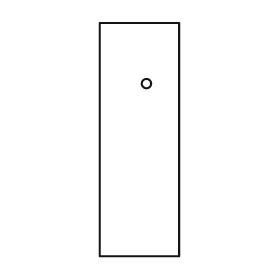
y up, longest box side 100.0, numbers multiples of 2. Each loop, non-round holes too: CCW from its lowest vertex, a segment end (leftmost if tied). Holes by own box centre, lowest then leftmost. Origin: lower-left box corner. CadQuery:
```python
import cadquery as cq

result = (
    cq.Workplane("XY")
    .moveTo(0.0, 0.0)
    .lineTo(34.0, 0.0)
    .lineTo(34.0, 100.0)
    .lineTo(0.0, 100.0)
    .close()
    .moveTo(20.0, 74.0)
    .circle(2.0)
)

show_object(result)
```